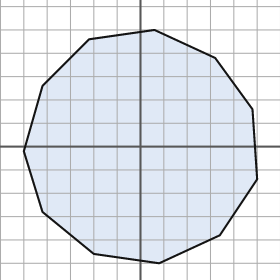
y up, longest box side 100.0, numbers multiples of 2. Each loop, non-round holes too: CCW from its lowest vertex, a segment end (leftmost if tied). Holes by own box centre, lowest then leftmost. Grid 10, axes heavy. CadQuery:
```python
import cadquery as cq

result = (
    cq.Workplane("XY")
    .moveTo(8.0, -50.0)
    .lineTo(34.0, -38.0)
    .lineTo(50.0, -14.0)
    .lineTo(48.0, 16.0)
    .lineTo(32.0, 38.0)
    .lineTo(6.0, 50.0)
    .lineTo(-22.0, 46.0)
    .lineTo(-42.0, 26.0)
    .lineTo(-50.0, -2.0)
    .lineTo(-42.0, -28.0)
    .lineTo(-20.0, -46.0)
    .close()
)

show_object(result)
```